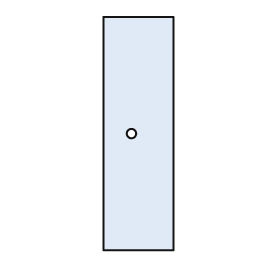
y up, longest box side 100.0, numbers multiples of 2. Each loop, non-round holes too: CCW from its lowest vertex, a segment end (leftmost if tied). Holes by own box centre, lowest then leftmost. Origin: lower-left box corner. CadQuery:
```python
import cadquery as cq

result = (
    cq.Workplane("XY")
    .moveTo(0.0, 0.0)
    .lineTo(30.0, 0.0)
    .lineTo(30.0, 100.0)
    .lineTo(0.0, 100.0)
    .close()
    .moveTo(12.0, 50.0)
    .circle(2.0)
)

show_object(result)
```